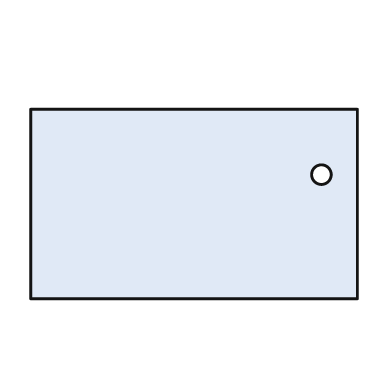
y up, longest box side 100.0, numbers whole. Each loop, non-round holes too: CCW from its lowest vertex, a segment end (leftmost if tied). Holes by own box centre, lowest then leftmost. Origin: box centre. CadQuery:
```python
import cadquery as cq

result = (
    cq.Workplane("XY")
    .moveTo(-50.0, -29.0)
    .lineTo(50.0, -29.0)
    .lineTo(50.0, 29.0)
    .lineTo(-50.0, 29.0)
    .close()
    .moveTo(39.0, 9.0)
    .circle(3.0)
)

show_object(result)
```